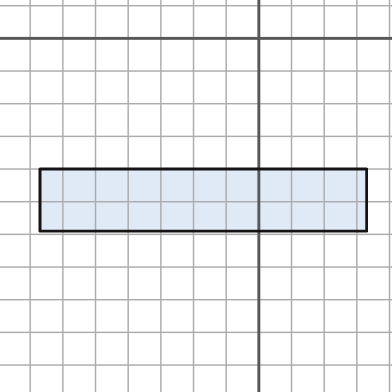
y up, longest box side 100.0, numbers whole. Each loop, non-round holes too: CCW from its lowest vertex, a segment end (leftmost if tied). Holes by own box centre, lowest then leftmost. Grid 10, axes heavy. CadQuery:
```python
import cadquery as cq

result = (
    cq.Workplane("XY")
    .moveTo(-67.0, -59.0)
    .lineTo(33.0, -59.0)
    .lineTo(33.0, -40.0)
    .lineTo(-67.0, -40.0)
    .close()
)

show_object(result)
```